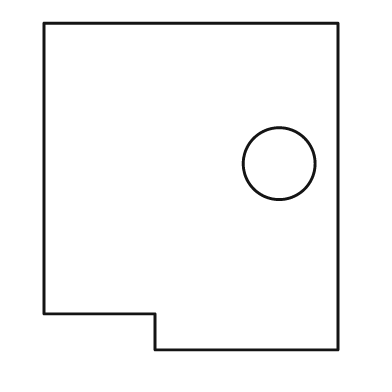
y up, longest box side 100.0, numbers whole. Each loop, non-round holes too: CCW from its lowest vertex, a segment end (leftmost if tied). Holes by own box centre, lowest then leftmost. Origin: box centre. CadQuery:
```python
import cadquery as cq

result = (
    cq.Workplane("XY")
    .moveTo(-11.0, -50.0)
    .lineTo(45.0, -50.0)
    .lineTo(45.0, 50.0)
    .lineTo(-45.0, 50.0)
    .lineTo(-45.0, -39.0)
    .lineTo(-11.0, -39.0)
    .close()
    .moveTo(27.0, 7.0)
    .circle(11.0)
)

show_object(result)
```